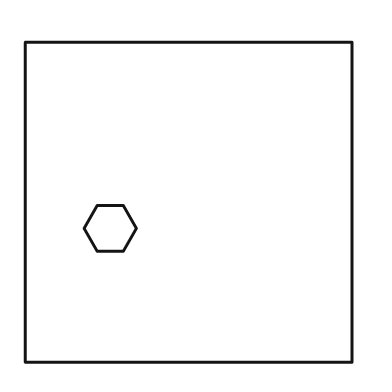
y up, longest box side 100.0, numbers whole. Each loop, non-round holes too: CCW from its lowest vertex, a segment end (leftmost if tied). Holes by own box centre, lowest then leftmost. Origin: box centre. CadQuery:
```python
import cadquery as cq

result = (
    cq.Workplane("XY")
    .moveTo(-50.0, -49.0)
    .lineTo(50.0, -49.0)
    .lineTo(50.0, 49.0)
    .lineTo(-50.0, 49.0)
    .close()
    .moveTo(-28.0, -15.0)
    .lineTo(-20.0, -15.0)
    .lineTo(-16.0, -8.0)
    .lineTo(-20.0, -1.0)
    .lineTo(-28.0, -1.0)
    .lineTo(-32.0, -8.0)
    .close()
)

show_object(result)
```